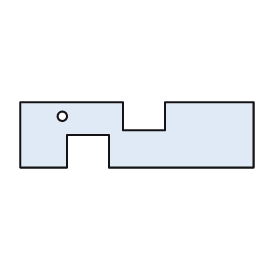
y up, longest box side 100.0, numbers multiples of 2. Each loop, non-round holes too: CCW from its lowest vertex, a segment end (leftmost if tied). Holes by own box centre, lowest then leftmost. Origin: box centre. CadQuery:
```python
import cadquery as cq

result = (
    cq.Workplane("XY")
    .moveTo(-50.0, -14.0)
    .lineTo(-30.0, -14.0)
    .lineTo(-30.0, 0.0)
    .lineTo(-12.0, 0.0)
    .lineTo(-12.0, -14.0)
    .lineTo(50.0, -14.0)
    .lineTo(50.0, 14.0)
    .lineTo(12.0, 14.0)
    .lineTo(12.0, 2.0)
    .lineTo(-6.0, 2.0)
    .lineTo(-6.0, 14.0)
    .lineTo(-50.0, 14.0)
    .close()
    .moveTo(-32.0, 8.0)
    .circle(2.0)
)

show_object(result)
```